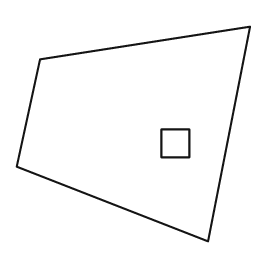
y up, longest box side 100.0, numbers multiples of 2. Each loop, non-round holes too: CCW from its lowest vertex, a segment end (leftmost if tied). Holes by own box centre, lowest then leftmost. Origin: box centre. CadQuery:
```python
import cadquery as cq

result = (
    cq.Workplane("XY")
    .moveTo(32.0, -46.0)
    .lineTo(50.0, 46.0)
    .lineTo(-40.0, 32.0)
    .lineTo(-50.0, -14.0)
    .close()
    .moveTo(12.0, -10.0)
    .lineTo(24.0, -10.0)
    .lineTo(24.0, 2.0)
    .lineTo(12.0, 2.0)
    .close()
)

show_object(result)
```